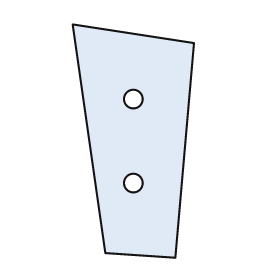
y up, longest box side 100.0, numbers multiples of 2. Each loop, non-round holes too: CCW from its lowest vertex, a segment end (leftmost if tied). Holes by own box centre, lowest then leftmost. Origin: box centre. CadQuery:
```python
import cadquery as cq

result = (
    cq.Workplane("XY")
    .moveTo(18.0, -50.0)
    .lineTo(26.0, 42.0)
    .lineTo(-26.0, 50.0)
    .lineTo(-12.0, -48.0)
    .close()
    .moveTo(0.0, -18.0)
    .circle(4.0)
    .moveTo(0.0, 18.0)
    .circle(4.0)
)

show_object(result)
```